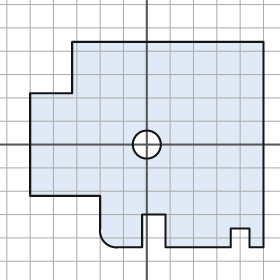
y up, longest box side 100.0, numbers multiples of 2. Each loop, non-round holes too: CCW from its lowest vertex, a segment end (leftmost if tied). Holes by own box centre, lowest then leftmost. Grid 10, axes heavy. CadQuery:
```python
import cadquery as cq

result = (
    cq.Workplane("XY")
    .moveTo(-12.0, -44.0)
    .lineTo(-2.0, -44.0)
    .lineTo(-2.0, -30.0)
    .lineTo(8.0, -30.0)
    .lineTo(8.0, -44.0)
    .lineTo(36.0, -44.0)
    .lineTo(36.0, -36.0)
    .lineTo(44.0, -36.0)
    .lineTo(44.0, -44.0)
    .lineTo(50.0, -44.0)
    .lineTo(50.0, 44.0)
    .lineTo(-32.0, 44.0)
    .lineTo(-32.0, 22.0)
    .lineTo(-50.0, 22.0)
    .lineTo(-50.0, -22.0)
    .lineTo(-20.0, -22.0)
    .lineTo(-20.0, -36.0)
    .threePointArc((-18.0, -42.0), (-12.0, -44.0))
    .close()
    .moveTo(0.0, 0.0)
    .circle(6.0)
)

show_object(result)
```